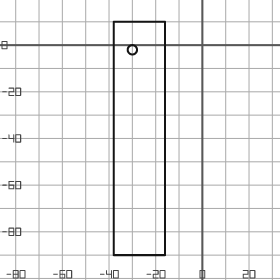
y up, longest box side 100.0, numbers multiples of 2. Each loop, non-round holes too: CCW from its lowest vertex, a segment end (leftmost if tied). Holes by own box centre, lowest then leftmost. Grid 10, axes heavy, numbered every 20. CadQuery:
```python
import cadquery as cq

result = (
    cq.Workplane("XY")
    .moveTo(-38.0, -90.0)
    .lineTo(-16.0, -90.0)
    .lineTo(-16.0, 10.0)
    .lineTo(-38.0, 10.0)
    .close()
    .moveTo(-30.0, -2.0)
    .circle(2.0)
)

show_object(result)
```